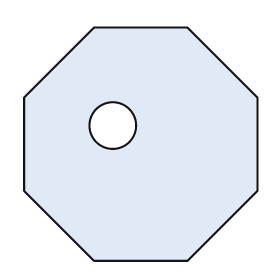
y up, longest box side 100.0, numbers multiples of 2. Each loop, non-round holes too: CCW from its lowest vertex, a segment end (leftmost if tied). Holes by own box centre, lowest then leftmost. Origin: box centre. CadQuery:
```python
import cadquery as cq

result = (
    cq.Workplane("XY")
    .moveTo(-20.0, -50.0)
    .lineTo(20.0, -50.0)
    .lineTo(50.0, -20.0)
    .lineTo(50.0, 20.0)
    .lineTo(20.0, 50.0)
    .lineTo(-20.0, 50.0)
    .lineTo(-50.0, 20.0)
    .lineTo(-50.0, -20.0)
    .close()
    .moveTo(-12.0, 8.0)
    .circle(10.0)
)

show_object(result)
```